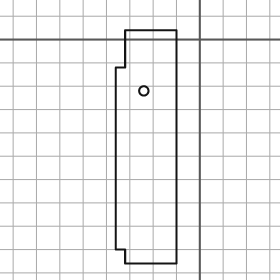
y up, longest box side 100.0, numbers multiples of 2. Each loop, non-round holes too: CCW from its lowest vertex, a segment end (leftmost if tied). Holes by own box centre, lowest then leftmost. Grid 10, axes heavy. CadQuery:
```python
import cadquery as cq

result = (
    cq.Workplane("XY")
    .moveTo(-32.0, -96.0)
    .lineTo(-10.0, -96.0)
    .lineTo(-10.0, 4.0)
    .lineTo(-32.0, 4.0)
    .lineTo(-32.0, -12.0)
    .lineTo(-36.0, -12.0)
    .lineTo(-36.0, -90.0)
    .lineTo(-32.0, -90.0)
    .close()
    .moveTo(-24.0, -22.0)
    .circle(2.0)
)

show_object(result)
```